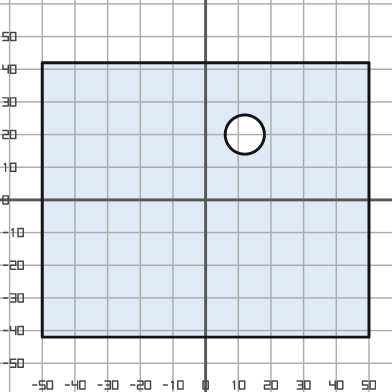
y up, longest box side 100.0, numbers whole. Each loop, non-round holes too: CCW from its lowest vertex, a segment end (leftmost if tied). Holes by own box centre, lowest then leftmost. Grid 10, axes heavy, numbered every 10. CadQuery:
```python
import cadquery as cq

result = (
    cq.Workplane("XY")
    .moveTo(-50.0, -42.0)
    .lineTo(50.0, -42.0)
    .lineTo(50.0, 42.0)
    .lineTo(-50.0, 42.0)
    .close()
    .moveTo(12.0, 20.0)
    .circle(6.0)
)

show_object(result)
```